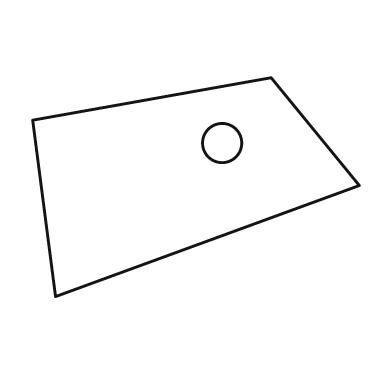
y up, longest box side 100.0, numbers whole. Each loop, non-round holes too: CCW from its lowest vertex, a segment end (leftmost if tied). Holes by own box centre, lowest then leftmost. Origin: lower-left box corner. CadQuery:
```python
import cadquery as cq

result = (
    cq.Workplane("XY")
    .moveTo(7.0, 0.0)
    .lineTo(100.0, 34.0)
    .lineTo(73.0, 67.0)
    .lineTo(0.0, 54.0)
    .close()
    .moveTo(58.0, 47.0)
    .circle(6.0)
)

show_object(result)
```